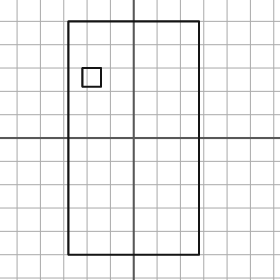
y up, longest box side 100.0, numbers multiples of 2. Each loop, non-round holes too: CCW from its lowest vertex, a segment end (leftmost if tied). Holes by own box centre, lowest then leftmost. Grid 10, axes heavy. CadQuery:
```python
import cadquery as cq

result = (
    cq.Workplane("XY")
    .moveTo(-28.0, -50.0)
    .lineTo(28.0, -50.0)
    .lineTo(28.0, 50.0)
    .lineTo(-28.0, 50.0)
    .close()
    .moveTo(-22.0, 22.0)
    .lineTo(-14.0, 22.0)
    .lineTo(-14.0, 30.0)
    .lineTo(-22.0, 30.0)
    .close()
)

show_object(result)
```